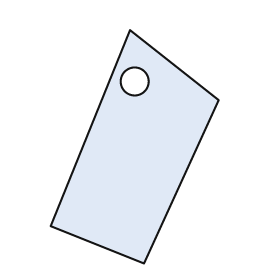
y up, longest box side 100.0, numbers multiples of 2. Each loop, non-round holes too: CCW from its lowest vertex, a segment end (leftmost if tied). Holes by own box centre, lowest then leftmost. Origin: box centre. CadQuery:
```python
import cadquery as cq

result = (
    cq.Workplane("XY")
    .moveTo(4.0, -50.0)
    .lineTo(36.0, 20.0)
    .lineTo(-2.0, 50.0)
    .lineTo(-36.0, -34.0)
    .close()
    .moveTo(0.0, 28.0)
    .circle(6.0)
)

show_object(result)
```